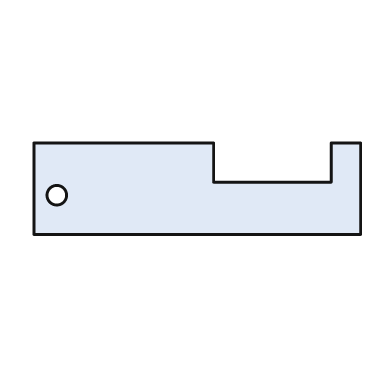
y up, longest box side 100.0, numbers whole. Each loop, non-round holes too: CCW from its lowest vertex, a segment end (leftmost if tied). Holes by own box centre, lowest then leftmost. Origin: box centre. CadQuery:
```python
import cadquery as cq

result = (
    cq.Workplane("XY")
    .moveTo(-50.0, -14.0)
    .lineTo(50.0, -14.0)
    .lineTo(50.0, 14.0)
    .lineTo(41.0, 14.0)
    .lineTo(41.0, 2.0)
    .lineTo(5.0, 2.0)
    .lineTo(5.0, 14.0)
    .lineTo(-50.0, 14.0)
    .close()
    .moveTo(-43.0, -2.0)
    .circle(3.0)
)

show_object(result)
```